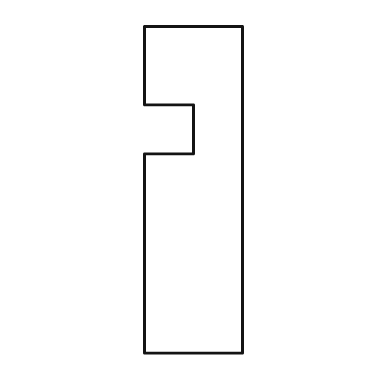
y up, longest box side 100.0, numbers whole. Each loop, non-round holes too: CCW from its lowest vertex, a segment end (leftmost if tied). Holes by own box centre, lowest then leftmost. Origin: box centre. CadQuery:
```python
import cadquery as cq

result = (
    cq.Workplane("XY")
    .moveTo(-15.0, -50.0)
    .lineTo(15.0, -50.0)
    .lineTo(15.0, 50.0)
    .lineTo(-15.0, 50.0)
    .lineTo(-15.0, 26.0)
    .lineTo(0.0, 26.0)
    .lineTo(0.0, 11.0)
    .lineTo(-15.0, 11.0)
    .close()
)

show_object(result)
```